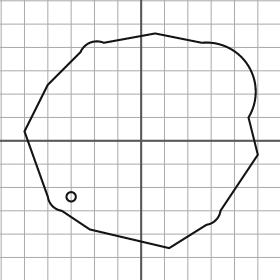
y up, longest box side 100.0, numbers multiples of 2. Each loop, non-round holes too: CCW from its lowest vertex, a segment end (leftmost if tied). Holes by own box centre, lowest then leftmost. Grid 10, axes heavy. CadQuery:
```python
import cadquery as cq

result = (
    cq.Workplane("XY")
    .moveTo(12.0, -46.0)
    .lineTo(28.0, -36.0)
    .threePointArc((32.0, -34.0), (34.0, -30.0))
    .lineTo(50.0, -6.0)
    .lineTo(46.0, 10.0)
    .threePointArc((46.0, 32.0), (26.0, 42.0))
    .lineTo(6.0, 46.0)
    .lineTo(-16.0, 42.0)
    .threePointArc((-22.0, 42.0), (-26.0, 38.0))
    .lineTo(-40.0, 24.0)
    .lineTo(-50.0, 4.0)
    .lineTo(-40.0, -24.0)
    .threePointArc((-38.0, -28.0), (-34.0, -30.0))
    .lineTo(-22.0, -38.0)
    .close()
    .moveTo(-30.0, -24.0)
    .circle(2.0)
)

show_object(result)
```